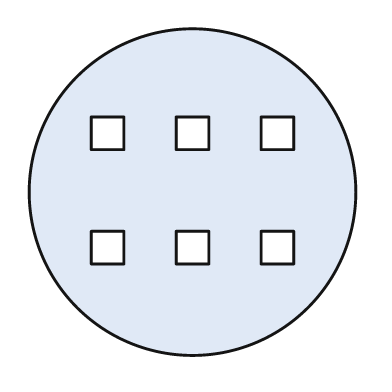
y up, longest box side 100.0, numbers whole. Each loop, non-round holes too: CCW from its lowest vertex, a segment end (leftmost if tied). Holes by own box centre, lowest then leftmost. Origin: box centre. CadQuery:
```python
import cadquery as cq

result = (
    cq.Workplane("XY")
    .moveTo(0.0, 0.0)
    .circle(50.0)
    .moveTo(-31.0, -22.0)
    .lineTo(-21.0, -22.0)
    .lineTo(-21.0, -12.0)
    .lineTo(-31.0, -12.0)
    .close()
    .moveTo(-5.0, -22.0)
    .lineTo(5.0, -22.0)
    .lineTo(5.0, -12.0)
    .lineTo(-5.0, -12.0)
    .close()
    .moveTo(21.0, -22.0)
    .lineTo(31.0, -22.0)
    .lineTo(31.0, -12.0)
    .lineTo(21.0, -12.0)
    .close()
    .moveTo(-31.0, 13.0)
    .lineTo(-21.0, 13.0)
    .lineTo(-21.0, 23.0)
    .lineTo(-31.0, 23.0)
    .close()
    .moveTo(-5.0, 13.0)
    .lineTo(5.0, 13.0)
    .lineTo(5.0, 23.0)
    .lineTo(-5.0, 23.0)
    .close()
    .moveTo(21.0, 13.0)
    .lineTo(31.0, 13.0)
    .lineTo(31.0, 23.0)
    .lineTo(21.0, 23.0)
    .close()
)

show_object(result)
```